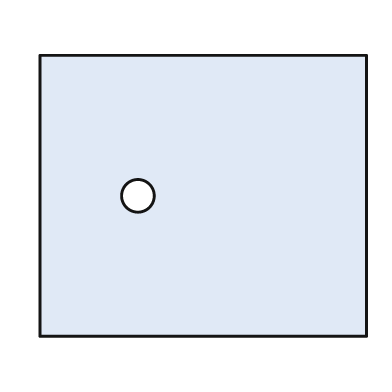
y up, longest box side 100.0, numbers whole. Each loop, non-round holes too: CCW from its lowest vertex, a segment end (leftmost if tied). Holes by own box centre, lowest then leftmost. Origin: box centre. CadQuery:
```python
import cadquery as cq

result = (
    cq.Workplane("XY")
    .moveTo(-50.0, -43.0)
    .lineTo(50.0, -43.0)
    .lineTo(50.0, 43.0)
    .lineTo(-50.0, 43.0)
    .close()
    .moveTo(-20.0, 0.0)
    .circle(5.0)
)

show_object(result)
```